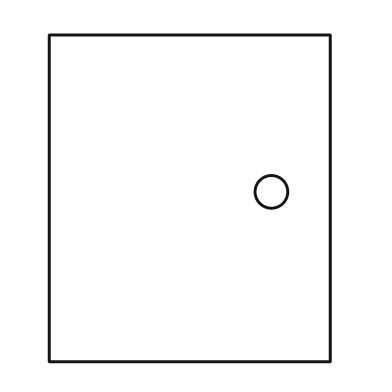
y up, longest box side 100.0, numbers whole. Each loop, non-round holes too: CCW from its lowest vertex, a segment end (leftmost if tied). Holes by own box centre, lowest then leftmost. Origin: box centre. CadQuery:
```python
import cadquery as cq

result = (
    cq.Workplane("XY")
    .moveTo(-43.0, -50.0)
    .lineTo(43.0, -50.0)
    .lineTo(43.0, 50.0)
    .lineTo(-43.0, 50.0)
    .close()
    .moveTo(25.0, 2.0)
    .circle(5.0)
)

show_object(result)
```